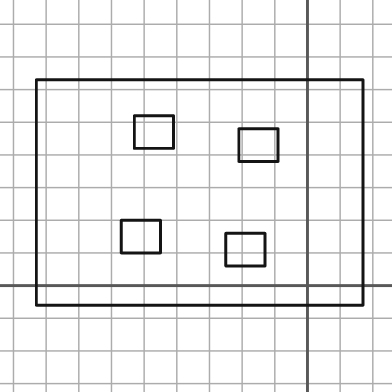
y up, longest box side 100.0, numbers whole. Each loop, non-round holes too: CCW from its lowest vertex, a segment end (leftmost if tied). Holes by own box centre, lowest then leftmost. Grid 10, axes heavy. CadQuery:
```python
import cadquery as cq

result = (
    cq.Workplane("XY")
    .moveTo(-83.0, -6.0)
    .lineTo(17.0, -6.0)
    .lineTo(17.0, 63.0)
    .lineTo(-83.0, 63.0)
    .close()
    .moveTo(-25.0, 6.0)
    .lineTo(-13.0, 6.0)
    .lineTo(-13.0, 16.0)
    .lineTo(-25.0, 16.0)
    .close()
    .moveTo(-57.0, 10.0)
    .lineTo(-45.0, 10.0)
    .lineTo(-45.0, 20.0)
    .lineTo(-57.0, 20.0)
    .close()
    .moveTo(-21.0, 38.0)
    .lineTo(-9.0, 38.0)
    .lineTo(-9.0, 48.0)
    .lineTo(-21.0, 48.0)
    .close()
    .moveTo(-53.0, 42.0)
    .lineTo(-41.0, 42.0)
    .lineTo(-41.0, 52.0)
    .lineTo(-53.0, 52.0)
    .close()
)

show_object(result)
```